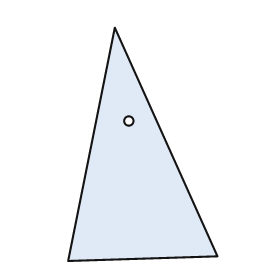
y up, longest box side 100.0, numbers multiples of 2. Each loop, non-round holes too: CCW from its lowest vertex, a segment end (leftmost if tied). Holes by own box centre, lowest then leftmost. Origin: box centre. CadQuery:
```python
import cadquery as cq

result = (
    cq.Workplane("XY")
    .moveTo(-32.0, -50.0)
    .lineTo(32.0, -48.0)
    .lineTo(-12.0, 50.0)
    .close()
    .moveTo(-6.0, 10.0)
    .circle(2.0)
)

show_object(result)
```